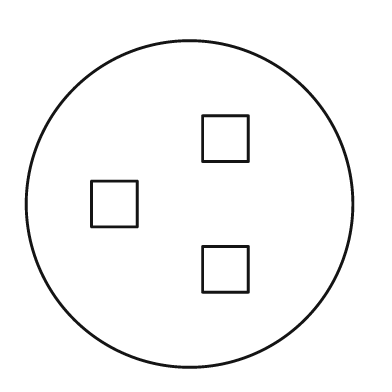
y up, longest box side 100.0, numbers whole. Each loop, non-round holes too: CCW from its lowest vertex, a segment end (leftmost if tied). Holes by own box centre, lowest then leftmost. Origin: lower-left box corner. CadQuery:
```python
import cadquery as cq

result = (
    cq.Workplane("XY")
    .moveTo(50.0, 50.0)
    .circle(50.0)
    .moveTo(54.0, 23.0)
    .lineTo(68.0, 23.0)
    .lineTo(68.0, 37.0)
    .lineTo(54.0, 37.0)
    .close()
    .moveTo(20.0, 43.0)
    .lineTo(34.0, 43.0)
    .lineTo(34.0, 57.0)
    .lineTo(20.0, 57.0)
    .close()
    .moveTo(54.0, 63.0)
    .lineTo(68.0, 63.0)
    .lineTo(68.0, 77.0)
    .lineTo(54.0, 77.0)
    .close()
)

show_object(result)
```